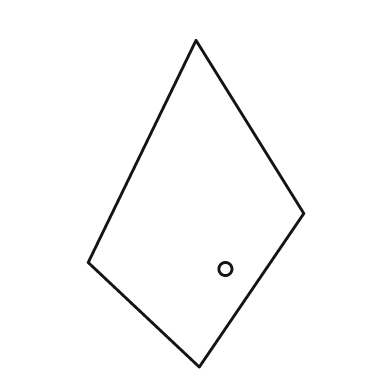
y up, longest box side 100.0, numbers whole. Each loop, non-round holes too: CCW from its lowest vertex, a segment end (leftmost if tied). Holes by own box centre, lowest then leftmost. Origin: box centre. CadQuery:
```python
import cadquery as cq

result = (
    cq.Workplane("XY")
    .moveTo(1.0, -50.0)
    .lineTo(33.0, -3.0)
    .lineTo(0.0, 50.0)
    .lineTo(-33.0, -18.0)
    .close()
    .moveTo(9.0, -20.0)
    .circle(2.0)
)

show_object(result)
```